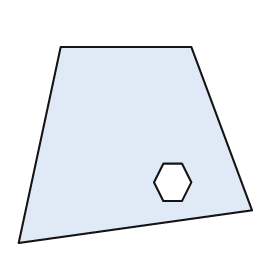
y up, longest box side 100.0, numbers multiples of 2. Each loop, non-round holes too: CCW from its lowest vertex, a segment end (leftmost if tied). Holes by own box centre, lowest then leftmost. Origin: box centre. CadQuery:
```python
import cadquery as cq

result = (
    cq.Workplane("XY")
    .moveTo(-50.0, -42.0)
    .lineTo(50.0, -28.0)
    .lineTo(24.0, 42.0)
    .lineTo(-32.0, 42.0)
    .close()
    .moveTo(12.0, -24.0)
    .lineTo(20.0, -24.0)
    .lineTo(24.0, -16.0)
    .lineTo(20.0, -8.0)
    .lineTo(12.0, -8.0)
    .lineTo(8.0, -16.0)
    .close()
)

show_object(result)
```